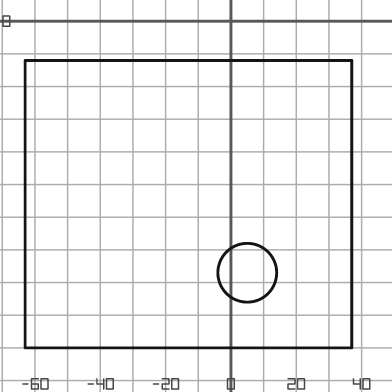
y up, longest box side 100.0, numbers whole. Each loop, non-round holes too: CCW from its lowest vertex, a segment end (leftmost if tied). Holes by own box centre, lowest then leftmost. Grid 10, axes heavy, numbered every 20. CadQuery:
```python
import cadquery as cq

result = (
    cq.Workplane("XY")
    .moveTo(-63.0, -100.0)
    .lineTo(37.0, -100.0)
    .lineTo(37.0, -12.0)
    .lineTo(-63.0, -12.0)
    .close()
    .moveTo(5.0, -77.0)
    .circle(9.0)
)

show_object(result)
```